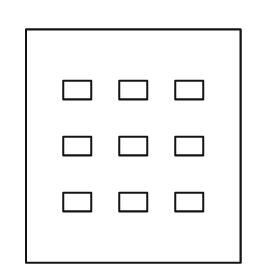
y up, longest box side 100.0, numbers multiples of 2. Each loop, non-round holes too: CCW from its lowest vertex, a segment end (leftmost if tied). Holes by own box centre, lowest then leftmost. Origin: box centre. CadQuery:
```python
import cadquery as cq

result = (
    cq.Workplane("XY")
    .moveTo(-46.0, -50.0)
    .lineTo(46.0, -50.0)
    .lineTo(46.0, 50.0)
    .lineTo(-46.0, 50.0)
    .close()
    .moveTo(-30.0, -28.0)
    .lineTo(-18.0, -28.0)
    .lineTo(-18.0, -20.0)
    .lineTo(-30.0, -20.0)
    .close()
    .moveTo(-6.0, -28.0)
    .lineTo(6.0, -28.0)
    .lineTo(6.0, -20.0)
    .lineTo(-6.0, -20.0)
    .close()
    .moveTo(18.0, -28.0)
    .lineTo(30.0, -28.0)
    .lineTo(30.0, -20.0)
    .lineTo(18.0, -20.0)
    .close()
    .moveTo(-30.0, -4.0)
    .lineTo(-18.0, -4.0)
    .lineTo(-18.0, 4.0)
    .lineTo(-30.0, 4.0)
    .close()
    .moveTo(-6.0, -4.0)
    .lineTo(6.0, -4.0)
    .lineTo(6.0, 4.0)
    .lineTo(-6.0, 4.0)
    .close()
    .moveTo(18.0, -4.0)
    .lineTo(30.0, -4.0)
    .lineTo(30.0, 4.0)
    .lineTo(18.0, 4.0)
    .close()
    .moveTo(-30.0, 20.0)
    .lineTo(-18.0, 20.0)
    .lineTo(-18.0, 28.0)
    .lineTo(-30.0, 28.0)
    .close()
    .moveTo(-6.0, 20.0)
    .lineTo(6.0, 20.0)
    .lineTo(6.0, 28.0)
    .lineTo(-6.0, 28.0)
    .close()
    .moveTo(18.0, 20.0)
    .lineTo(30.0, 20.0)
    .lineTo(30.0, 28.0)
    .lineTo(18.0, 28.0)
    .close()
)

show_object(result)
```